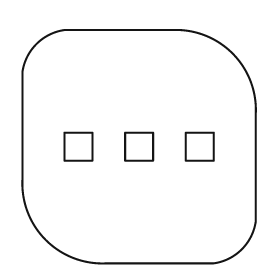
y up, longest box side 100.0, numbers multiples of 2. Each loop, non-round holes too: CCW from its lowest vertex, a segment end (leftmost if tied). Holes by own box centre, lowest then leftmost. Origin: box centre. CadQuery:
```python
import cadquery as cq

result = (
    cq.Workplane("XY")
    .moveTo(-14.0, -50.0)
    .lineTo(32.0, -50.0)
    .threePointArc((44.0, -44.0), (50.0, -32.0))
    .lineTo(50.0, 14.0)
    .threePointArc((40.0, 40.0), (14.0, 50.0))
    .lineTo(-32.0, 50.0)
    .threePointArc((-44.0, 44.0), (-50.0, 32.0))
    .lineTo(-50.0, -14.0)
    .threePointArc((-40.0, -40.0), (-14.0, -50.0))
    .close()
    .moveTo(-32.0, -6.0)
    .lineTo(-20.0, -6.0)
    .lineTo(-20.0, 6.0)
    .lineTo(-32.0, 6.0)
    .close()
    .moveTo(-6.0, -6.0)
    .lineTo(6.0, -6.0)
    .lineTo(6.0, 6.0)
    .lineTo(-6.0, 6.0)
    .close()
    .moveTo(20.0, -6.0)
    .lineTo(32.0, -6.0)
    .lineTo(32.0, 6.0)
    .lineTo(20.0, 6.0)
    .close()
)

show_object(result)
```